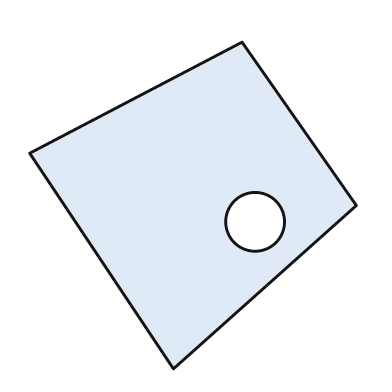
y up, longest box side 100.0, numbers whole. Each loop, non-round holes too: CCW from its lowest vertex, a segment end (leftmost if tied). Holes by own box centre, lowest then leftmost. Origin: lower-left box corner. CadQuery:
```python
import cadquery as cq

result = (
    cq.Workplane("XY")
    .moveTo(44.0, 0.0)
    .lineTo(100.0, 50.0)
    .lineTo(65.0, 100.0)
    .lineTo(0.0, 66.0)
    .close()
    .moveTo(69.0, 45.0)
    .circle(9.0)
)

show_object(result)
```